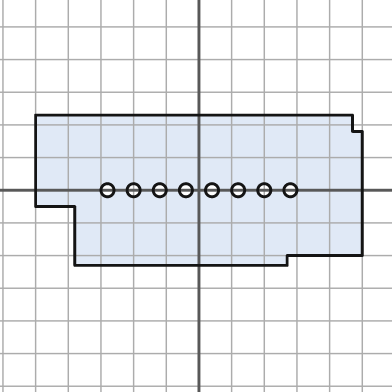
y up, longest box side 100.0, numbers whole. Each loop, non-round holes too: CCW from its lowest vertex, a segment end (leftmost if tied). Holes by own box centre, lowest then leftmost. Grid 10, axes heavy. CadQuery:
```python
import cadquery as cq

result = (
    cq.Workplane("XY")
    .moveTo(-38.0, -23.0)
    .lineTo(27.0, -23.0)
    .lineTo(27.0, -20.0)
    .lineTo(50.0, -20.0)
    .lineTo(50.0, 18.0)
    .lineTo(47.0, 18.0)
    .lineTo(47.0, 23.0)
    .lineTo(-50.0, 23.0)
    .lineTo(-50.0, -5.0)
    .lineTo(-38.0, -5.0)
    .close()
    .moveTo(-28.0, 0.0)
    .circle(2.0)
    .moveTo(-20.0, 0.0)
    .circle(2.0)
    .moveTo(-12.0, 0.0)
    .circle(2.0)
    .moveTo(-4.0, 0.0)
    .circle(2.0)
    .moveTo(4.0, 0.0)
    .circle(2.0)
    .moveTo(12.0, 0.0)
    .circle(2.0)
    .moveTo(20.0, 0.0)
    .circle(2.0)
    .moveTo(28.0, 0.0)
    .circle(2.0)
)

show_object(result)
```